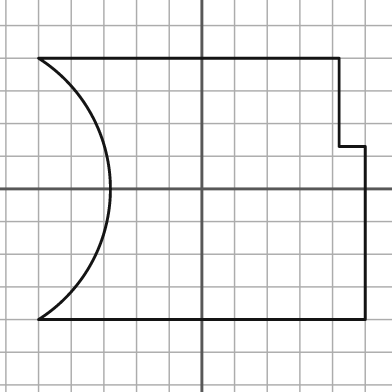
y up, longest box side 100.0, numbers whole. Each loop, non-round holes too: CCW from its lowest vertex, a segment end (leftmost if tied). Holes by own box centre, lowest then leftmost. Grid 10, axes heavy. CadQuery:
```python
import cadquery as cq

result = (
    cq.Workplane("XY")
    .moveTo(-50.0, -40.0)
    .lineTo(50.0, -40.0)
    .lineTo(50.0, 13.0)
    .lineTo(42.0, 13.0)
    .lineTo(42.0, 40.0)
    .lineTo(-50.0, 40.0)
    .threePointArc((-28.0, 0.0), (-50.0, -40.0))
    .close()
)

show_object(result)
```